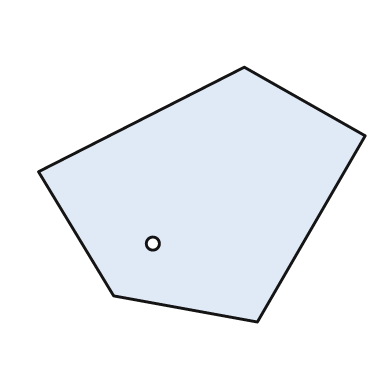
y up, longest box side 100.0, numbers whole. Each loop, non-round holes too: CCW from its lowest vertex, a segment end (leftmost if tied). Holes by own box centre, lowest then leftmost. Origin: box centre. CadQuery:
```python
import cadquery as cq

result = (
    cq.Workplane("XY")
    .moveTo(17.0, -39.0)
    .lineTo(50.0, 18.0)
    .lineTo(13.0, 39.0)
    .lineTo(-50.0, 7.0)
    .lineTo(-27.0, -31.0)
    .close()
    .moveTo(-15.0, -15.0)
    .circle(2.0)
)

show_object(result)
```